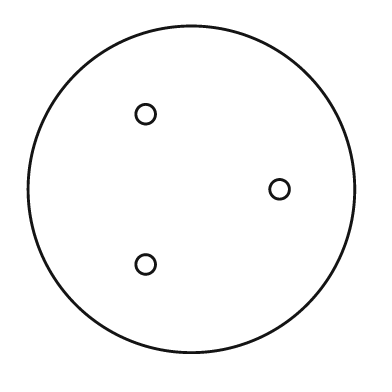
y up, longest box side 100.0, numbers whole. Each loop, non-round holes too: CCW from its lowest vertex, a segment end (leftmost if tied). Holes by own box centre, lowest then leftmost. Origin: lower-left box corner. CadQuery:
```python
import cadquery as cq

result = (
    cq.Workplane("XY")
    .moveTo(50.0, 50.0)
    .circle(50.0)
    .moveTo(36.0, 27.0)
    .circle(3.0)
    .moveTo(77.0, 50.0)
    .circle(3.0)
    .moveTo(36.0, 73.0)
    .circle(3.0)
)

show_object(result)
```